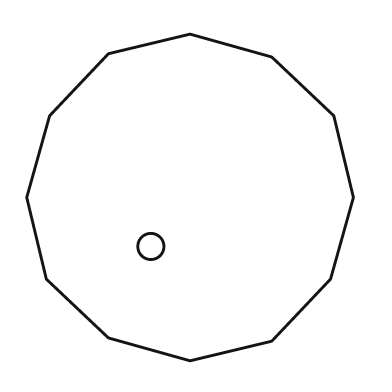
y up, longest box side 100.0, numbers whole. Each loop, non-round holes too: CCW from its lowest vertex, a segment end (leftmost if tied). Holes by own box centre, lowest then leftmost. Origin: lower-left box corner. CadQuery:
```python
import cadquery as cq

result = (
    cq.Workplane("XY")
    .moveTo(50.0, 0.0)
    .lineTo(75.0, 6.0)
    .lineTo(93.0, 25.0)
    .lineTo(100.0, 50.0)
    .lineTo(94.0, 75.0)
    .lineTo(75.0, 93.0)
    .lineTo(50.0, 100.0)
    .lineTo(25.0, 94.0)
    .lineTo(7.0, 75.0)
    .lineTo(0.0, 50.0)
    .lineTo(6.0, 25.0)
    .lineTo(25.0, 7.0)
    .close()
    .moveTo(38.0, 35.0)
    .circle(4.0)
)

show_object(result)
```